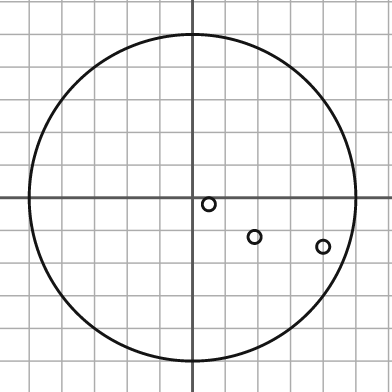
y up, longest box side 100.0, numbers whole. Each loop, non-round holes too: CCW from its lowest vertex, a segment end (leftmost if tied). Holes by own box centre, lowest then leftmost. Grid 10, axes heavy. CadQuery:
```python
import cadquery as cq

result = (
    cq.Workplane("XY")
    .moveTo(0.0, 0.0)
    .circle(50.0)
    .moveTo(40.0, -15.0)
    .circle(2.0)
    .moveTo(19.0, -12.0)
    .circle(2.0)
    .moveTo(5.0, -2.0)
    .circle(2.0)
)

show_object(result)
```